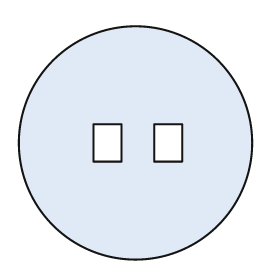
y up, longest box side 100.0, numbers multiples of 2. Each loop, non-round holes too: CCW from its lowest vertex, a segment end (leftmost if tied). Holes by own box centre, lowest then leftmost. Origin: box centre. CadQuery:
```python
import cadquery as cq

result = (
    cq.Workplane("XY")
    .moveTo(0.0, 0.0)
    .circle(50.0)
    .moveTo(-18.0, -8.0)
    .lineTo(-6.0, -8.0)
    .lineTo(-6.0, 8.0)
    .lineTo(-18.0, 8.0)
    .close()
    .moveTo(8.0, -8.0)
    .lineTo(20.0, -8.0)
    .lineTo(20.0, 8.0)
    .lineTo(8.0, 8.0)
    .close()
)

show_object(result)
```